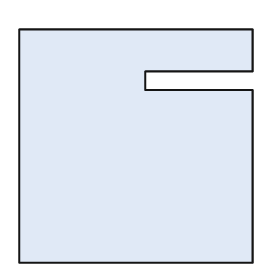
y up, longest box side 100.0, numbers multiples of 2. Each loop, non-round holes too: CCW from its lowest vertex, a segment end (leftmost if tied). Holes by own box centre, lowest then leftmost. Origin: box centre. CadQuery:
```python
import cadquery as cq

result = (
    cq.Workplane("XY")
    .moveTo(-50.0, -50.0)
    .lineTo(50.0, -50.0)
    .lineTo(50.0, 24.0)
    .lineTo(4.0, 24.0)
    .lineTo(4.0, 32.0)
    .lineTo(50.0, 32.0)
    .lineTo(50.0, 50.0)
    .lineTo(-50.0, 50.0)
    .close()
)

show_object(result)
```